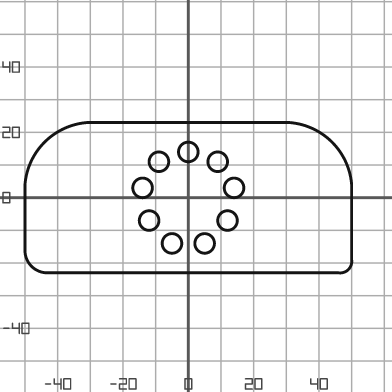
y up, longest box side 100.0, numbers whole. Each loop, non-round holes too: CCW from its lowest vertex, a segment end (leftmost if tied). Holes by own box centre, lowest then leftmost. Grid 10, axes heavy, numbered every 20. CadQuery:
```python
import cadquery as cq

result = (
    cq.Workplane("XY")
    .moveTo(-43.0, -23.0)
    .lineTo(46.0, -23.0)
    .threePointArc((49.0, -22.0), (50.0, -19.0))
    .lineTo(50.0, 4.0)
    .threePointArc((44.0, 17.0), (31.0, 23.0))
    .lineTo(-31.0, 23.0)
    .threePointArc((-44.0, 17.0), (-50.0, 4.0))
    .lineTo(-50.0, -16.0)
    .threePointArc((-48.0, -21.0), (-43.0, -23.0))
    .close()
    .moveTo(-5.0, -14.0)
    .circle(3.0)
    .moveTo(5.0, -14.0)
    .circle(3.0)
    .moveTo(-12.0, -7.0)
    .circle(3.0)
    .moveTo(12.0, -7.0)
    .circle(3.0)
    .moveTo(-14.0, 3.0)
    .circle(3.0)
    .moveTo(14.0, 3.0)
    .circle(3.0)
    .moveTo(-9.0, 11.0)
    .circle(3.0)
    .moveTo(9.0, 11.0)
    .circle(3.0)
    .moveTo(0.0, 14.0)
    .circle(3.0)
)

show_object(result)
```